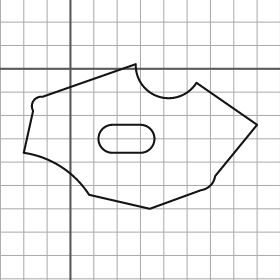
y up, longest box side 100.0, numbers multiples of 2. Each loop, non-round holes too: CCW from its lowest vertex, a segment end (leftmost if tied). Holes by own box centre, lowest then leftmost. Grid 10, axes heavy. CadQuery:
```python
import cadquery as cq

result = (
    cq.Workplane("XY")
    .moveTo(34.0, -60.0)
    .lineTo(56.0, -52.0)
    .threePointArc((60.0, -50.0), (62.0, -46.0))
    .lineTo(80.0, -24.0)
    .lineTo(54.0, -6.0)
    .threePointArc((38.0, -12.0), (28.0, 2.0))
    .lineTo(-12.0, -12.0)
    .threePointArc((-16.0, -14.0), (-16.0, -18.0))
    .lineTo(-20.0, -36.0)
    .threePointArc((-4.0, -42.0), (8.0, -54.0))
    .close()
    .moveTo(18.0, -36.0)
    .lineTo(30.0, -36.0)
    .threePointArc((36.0, -30.0), (30.0, -24.0))
    .lineTo(18.0, -24.0)
    .threePointArc((12.0, -30.0), (18.0, -36.0))
    .close()
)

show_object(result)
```